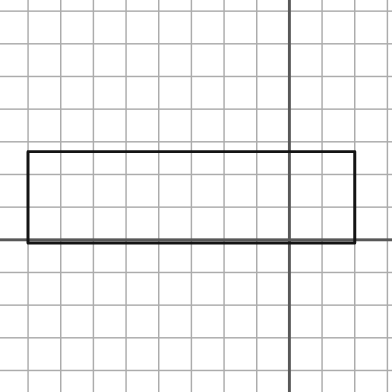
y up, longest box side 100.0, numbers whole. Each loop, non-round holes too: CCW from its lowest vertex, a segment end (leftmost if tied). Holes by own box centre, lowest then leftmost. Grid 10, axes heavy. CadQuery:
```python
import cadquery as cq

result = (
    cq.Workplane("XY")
    .moveTo(-80.0, -1.0)
    .lineTo(20.0, -1.0)
    .lineTo(20.0, 27.0)
    .lineTo(-80.0, 27.0)
    .close()
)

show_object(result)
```